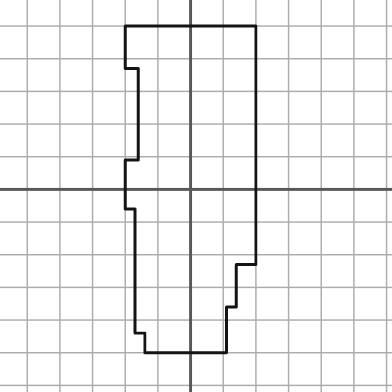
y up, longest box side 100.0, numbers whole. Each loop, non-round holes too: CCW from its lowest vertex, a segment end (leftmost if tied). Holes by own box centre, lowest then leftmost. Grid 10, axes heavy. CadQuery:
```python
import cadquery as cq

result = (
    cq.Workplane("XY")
    .moveTo(-14.0, -50.0)
    .lineTo(11.0, -50.0)
    .lineTo(11.0, -36.0)
    .lineTo(14.0, -36.0)
    .lineTo(14.0, -23.0)
    .lineTo(20.0, -23.0)
    .lineTo(20.0, 50.0)
    .lineTo(-20.0, 50.0)
    .lineTo(-20.0, 37.0)
    .lineTo(-16.0, 37.0)
    .lineTo(-16.0, 9.0)
    .lineTo(-20.0, 9.0)
    .lineTo(-20.0, -6.0)
    .lineTo(-17.0, -6.0)
    .lineTo(-17.0, -44.0)
    .lineTo(-14.0, -44.0)
    .close()
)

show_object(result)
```